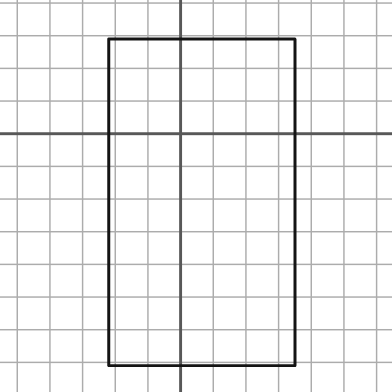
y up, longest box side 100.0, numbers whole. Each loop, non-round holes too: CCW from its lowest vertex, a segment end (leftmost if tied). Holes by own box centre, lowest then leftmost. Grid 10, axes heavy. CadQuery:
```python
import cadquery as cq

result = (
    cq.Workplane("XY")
    .moveTo(-22.0, -71.0)
    .lineTo(35.0, -71.0)
    .lineTo(35.0, 29.0)
    .lineTo(-22.0, 29.0)
    .close()
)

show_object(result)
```